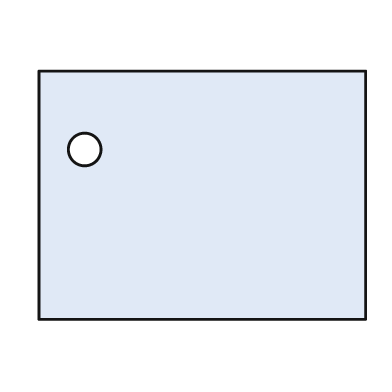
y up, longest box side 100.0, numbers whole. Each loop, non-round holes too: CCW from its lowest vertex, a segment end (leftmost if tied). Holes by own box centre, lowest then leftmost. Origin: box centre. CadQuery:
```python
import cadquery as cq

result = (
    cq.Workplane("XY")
    .moveTo(-50.0, -38.0)
    .lineTo(50.0, -38.0)
    .lineTo(50.0, 38.0)
    .lineTo(-50.0, 38.0)
    .close()
    .moveTo(-36.0, 14.0)
    .circle(5.0)
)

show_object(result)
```